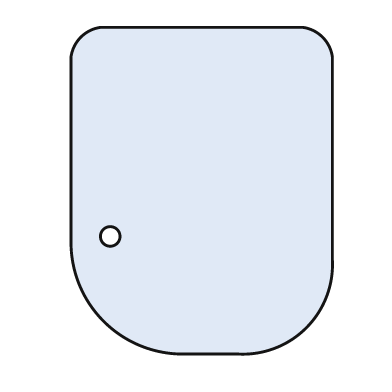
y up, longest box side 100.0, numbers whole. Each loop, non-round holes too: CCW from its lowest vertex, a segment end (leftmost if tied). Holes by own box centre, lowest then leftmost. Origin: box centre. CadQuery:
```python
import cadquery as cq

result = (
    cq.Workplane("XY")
    .moveTo(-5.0, -50.0)
    .lineTo(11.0, -50.0)
    .threePointArc((32.0, -42.0), (40.0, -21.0))
    .lineTo(40.0, 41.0)
    .threePointArc((37.0, 47.0), (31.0, 50.0))
    .lineTo(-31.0, 50.0)
    .threePointArc((-37.0, 47.0), (-40.0, 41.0))
    .lineTo(-40.0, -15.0)
    .threePointArc((-30.0, -40.0), (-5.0, -50.0))
    .close()
    .moveTo(-28.0, -14.0)
    .circle(3.0)
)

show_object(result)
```